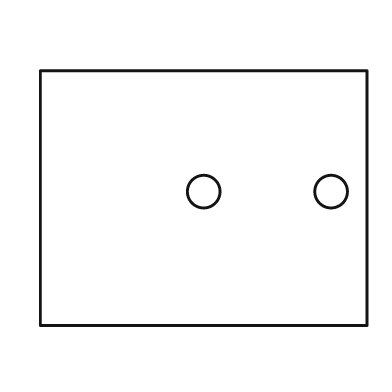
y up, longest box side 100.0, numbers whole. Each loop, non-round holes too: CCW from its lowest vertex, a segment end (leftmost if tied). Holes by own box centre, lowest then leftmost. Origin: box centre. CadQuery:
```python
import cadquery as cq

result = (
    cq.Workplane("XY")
    .moveTo(-50.0, -39.0)
    .lineTo(50.0, -39.0)
    .lineTo(50.0, 39.0)
    .lineTo(-50.0, 39.0)
    .close()
    .moveTo(0.0, 2.0)
    .circle(5.0)
    .moveTo(39.0, 2.0)
    .circle(5.0)
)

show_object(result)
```